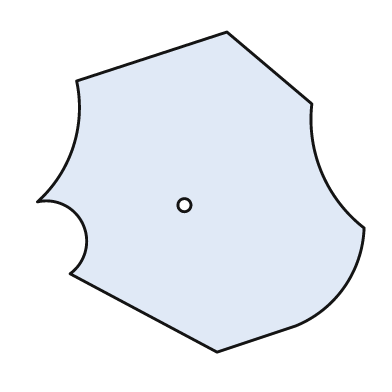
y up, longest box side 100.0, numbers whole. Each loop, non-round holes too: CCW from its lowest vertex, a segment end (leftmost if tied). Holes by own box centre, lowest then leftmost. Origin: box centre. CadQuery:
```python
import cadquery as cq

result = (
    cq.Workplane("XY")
    .moveTo(5.0, -49.0)
    .lineTo(29.0, -41.0)
    .threePointArc((44.0, -29.0), (50.0, -11.0))
    .threePointArc((37.0, 6.0), (34.0, 27.0))
    .lineTo(8.0, 49.0)
    .lineTo(-38.0, 34.0)
    .threePointArc((-39.0, 14.0), (-50.0, -3.0))
    .threePointArc((-36.0, -10.0), (-40.0, -25.0))
    .close()
    .moveTo(-5.0, -4.0)
    .circle(2.0)
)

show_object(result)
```